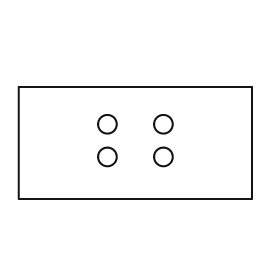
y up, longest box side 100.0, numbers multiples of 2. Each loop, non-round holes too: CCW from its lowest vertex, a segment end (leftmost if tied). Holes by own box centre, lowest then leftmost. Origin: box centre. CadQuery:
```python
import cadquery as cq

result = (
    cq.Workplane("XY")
    .moveTo(-50.0, -24.0)
    .lineTo(50.0, -24.0)
    .lineTo(50.0, 24.0)
    .lineTo(-50.0, 24.0)
    .close()
    .moveTo(-12.0, -6.0)
    .circle(4.0)
    .moveTo(12.0, -6.0)
    .circle(4.0)
    .moveTo(-12.0, 8.0)
    .circle(4.0)
    .moveTo(12.0, 8.0)
    .circle(4.0)
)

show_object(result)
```